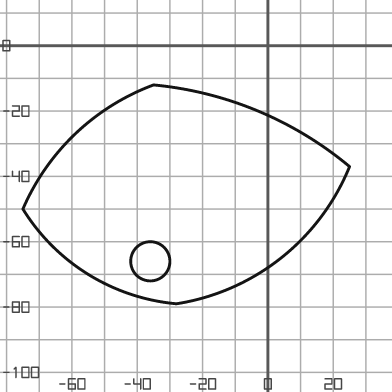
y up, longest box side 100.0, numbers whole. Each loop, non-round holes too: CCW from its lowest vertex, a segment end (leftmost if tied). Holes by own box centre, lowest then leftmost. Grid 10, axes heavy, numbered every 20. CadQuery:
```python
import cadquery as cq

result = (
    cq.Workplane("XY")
    .moveTo(-28.0, -79.0)
    .threePointArc((4.0, -65.0), (25.0, -37.0))
    .threePointArc((-3.0, -20.0), (-35.0, -12.0))
    .threePointArc((-59.0, -27.0), (-75.0, -50.0))
    .threePointArc((-55.0, -70.0), (-28.0, -79.0))
    .close()
    .moveTo(-36.0, -66.0)
    .circle(6.0)
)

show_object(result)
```